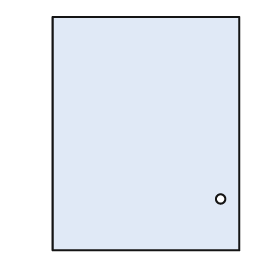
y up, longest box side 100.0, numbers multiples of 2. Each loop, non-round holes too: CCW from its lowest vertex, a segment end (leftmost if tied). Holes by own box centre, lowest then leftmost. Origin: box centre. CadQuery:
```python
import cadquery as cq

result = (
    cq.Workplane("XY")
    .moveTo(-40.0, -50.0)
    .lineTo(40.0, -50.0)
    .lineTo(40.0, 50.0)
    .lineTo(-40.0, 50.0)
    .close()
    .moveTo(32.0, -28.0)
    .circle(2.0)
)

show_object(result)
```